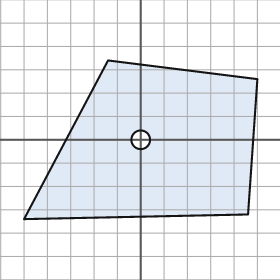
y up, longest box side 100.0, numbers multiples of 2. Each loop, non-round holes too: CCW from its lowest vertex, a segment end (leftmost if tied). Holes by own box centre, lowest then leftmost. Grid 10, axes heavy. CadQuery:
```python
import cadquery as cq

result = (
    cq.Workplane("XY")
    .moveTo(-50.0, -34.0)
    .lineTo(46.0, -32.0)
    .lineTo(50.0, 26.0)
    .lineTo(-14.0, 34.0)
    .close()
    .moveTo(0.0, 0.0)
    .circle(4.0)
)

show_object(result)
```